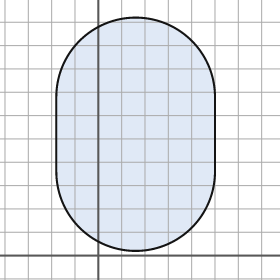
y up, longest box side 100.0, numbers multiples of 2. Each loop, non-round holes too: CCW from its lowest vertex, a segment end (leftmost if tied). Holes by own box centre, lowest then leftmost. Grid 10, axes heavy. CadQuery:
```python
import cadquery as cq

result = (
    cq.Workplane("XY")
    .moveTo(-18.0, 36.0)
    .threePointArc((16.0, 2.0), (50.0, 36.0))
    .lineTo(50.0, 68.0)
    .threePointArc((16.0, 102.0), (-18.0, 68.0))
    .close()
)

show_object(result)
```